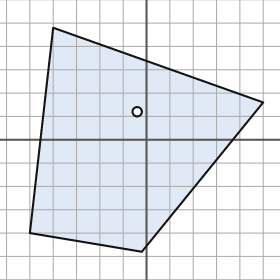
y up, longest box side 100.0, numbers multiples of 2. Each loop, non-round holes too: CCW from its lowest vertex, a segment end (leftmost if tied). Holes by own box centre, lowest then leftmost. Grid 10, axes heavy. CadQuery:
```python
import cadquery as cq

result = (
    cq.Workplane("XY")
    .moveTo(-2.0, -48.0)
    .lineTo(50.0, 16.0)
    .lineTo(-40.0, 48.0)
    .lineTo(-50.0, -40.0)
    .close()
    .moveTo(-4.0, 12.0)
    .circle(2.0)
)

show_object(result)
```